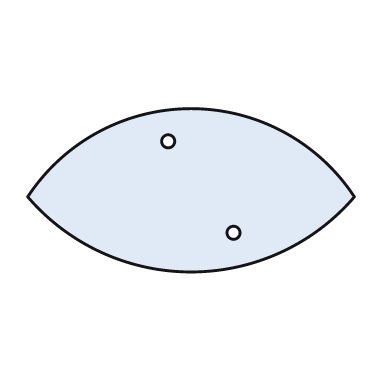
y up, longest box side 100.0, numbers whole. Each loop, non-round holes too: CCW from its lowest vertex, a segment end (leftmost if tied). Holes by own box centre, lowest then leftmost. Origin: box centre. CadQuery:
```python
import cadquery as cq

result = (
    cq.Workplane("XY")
    .moveTo(-50.0, -2.0)
    .threePointArc((0.0, -25.0), (50.0, -2.0))
    .threePointArc((0.0, 25.0), (-50.0, -2.0))
    .close()
    .moveTo(13.0, -13.0)
    .circle(2.0)
    .moveTo(-7.0, 15.0)
    .circle(2.0)
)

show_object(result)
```